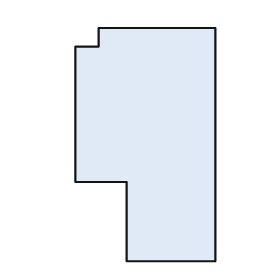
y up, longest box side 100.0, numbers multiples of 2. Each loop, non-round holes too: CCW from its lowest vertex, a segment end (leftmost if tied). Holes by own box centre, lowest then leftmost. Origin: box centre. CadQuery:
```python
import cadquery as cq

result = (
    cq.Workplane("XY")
    .moveTo(-8.0, -50.0)
    .lineTo(30.0, -50.0)
    .lineTo(30.0, 50.0)
    .lineTo(-20.0, 50.0)
    .lineTo(-20.0, 42.0)
    .lineTo(-30.0, 42.0)
    .lineTo(-30.0, -16.0)
    .lineTo(-8.0, -16.0)
    .close()
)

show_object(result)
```